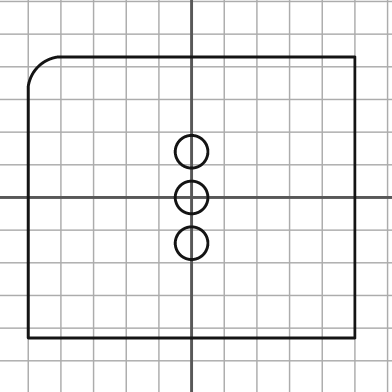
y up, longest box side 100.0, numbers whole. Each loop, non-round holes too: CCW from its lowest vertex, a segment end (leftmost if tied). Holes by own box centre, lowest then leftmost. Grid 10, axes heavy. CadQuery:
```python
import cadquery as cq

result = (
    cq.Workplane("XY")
    .moveTo(-50.0, -43.0)
    .lineTo(50.0, -43.0)
    .lineTo(50.0, 43.0)
    .lineTo(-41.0, 43.0)
    .threePointArc((-47.0, 40.0), (-50.0, 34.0))
    .close()
    .moveTo(0.0, -14.0)
    .circle(5.0)
    .moveTo(0.0, 0.0)
    .circle(5.0)
    .moveTo(0.0, 14.0)
    .circle(5.0)
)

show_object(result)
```